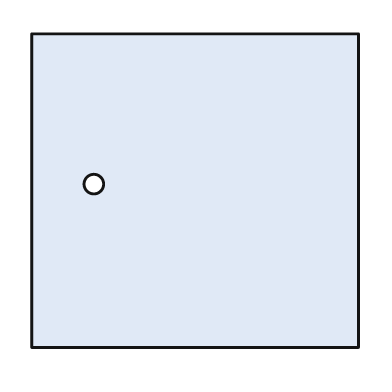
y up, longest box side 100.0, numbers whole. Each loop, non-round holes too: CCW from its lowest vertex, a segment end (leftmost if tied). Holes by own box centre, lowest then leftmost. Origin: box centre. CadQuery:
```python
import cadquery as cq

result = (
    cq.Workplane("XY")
    .moveTo(-50.0, -48.0)
    .lineTo(50.0, -48.0)
    .lineTo(50.0, 48.0)
    .lineTo(-50.0, 48.0)
    .close()
    .moveTo(-31.0, 2.0)
    .circle(3.0)
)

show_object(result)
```